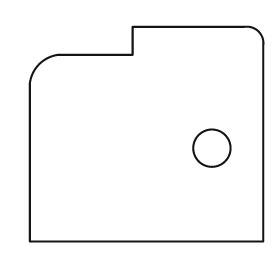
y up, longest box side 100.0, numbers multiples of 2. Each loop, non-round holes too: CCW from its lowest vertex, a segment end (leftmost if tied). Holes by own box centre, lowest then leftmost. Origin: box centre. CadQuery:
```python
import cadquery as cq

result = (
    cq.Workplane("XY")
    .moveTo(-50.0, -46.0)
    .lineTo(50.0, -46.0)
    .lineTo(50.0, 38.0)
    .threePointArc((48.0, 44.0), (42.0, 46.0))
    .lineTo(-6.0, 46.0)
    .lineTo(-6.0, 34.0)
    .lineTo(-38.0, 34.0)
    .threePointArc((-46.0, 30.0), (-50.0, 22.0))
    .close()
    .moveTo(28.0, -6.0)
    .circle(8.0)
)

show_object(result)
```